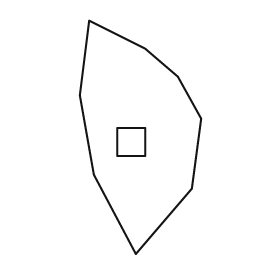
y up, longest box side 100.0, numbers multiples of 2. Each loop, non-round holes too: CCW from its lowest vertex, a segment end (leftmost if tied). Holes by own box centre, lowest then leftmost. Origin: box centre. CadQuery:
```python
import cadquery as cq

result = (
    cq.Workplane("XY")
    .moveTo(-2.0, -50.0)
    .lineTo(22.0, -22.0)
    .lineTo(26.0, 8.0)
    .lineTo(16.0, 26.0)
    .lineTo(2.0, 38.0)
    .lineTo(-22.0, 50.0)
    .lineTo(-26.0, 18.0)
    .lineTo(-20.0, -16.0)
    .close()
    .moveTo(-10.0, -8.0)
    .lineTo(2.0, -8.0)
    .lineTo(2.0, 4.0)
    .lineTo(-10.0, 4.0)
    .close()
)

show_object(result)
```